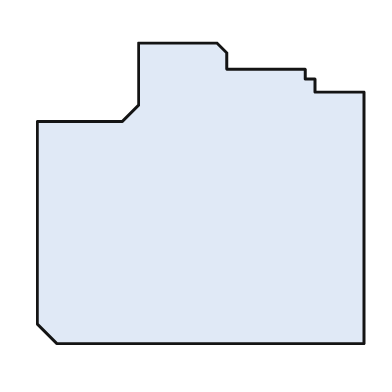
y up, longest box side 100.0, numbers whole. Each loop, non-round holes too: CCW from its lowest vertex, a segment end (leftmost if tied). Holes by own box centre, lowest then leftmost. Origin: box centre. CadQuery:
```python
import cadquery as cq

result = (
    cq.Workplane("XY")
    .moveTo(-44.0, -46.0)
    .lineTo(50.0, -46.0)
    .lineTo(50.0, 31.0)
    .lineTo(35.0, 31.0)
    .lineTo(35.0, 35.0)
    .lineTo(32.0, 35.0)
    .lineTo(32.0, 38.0)
    .lineTo(8.0, 38.0)
    .lineTo(8.0, 43.0)
    .lineTo(5.0, 46.0)
    .lineTo(-19.0, 46.0)
    .lineTo(-19.0, 27.0)
    .lineTo(-24.0, 22.0)
    .lineTo(-50.0, 22.0)
    .lineTo(-50.0, -40.0)
    .close()
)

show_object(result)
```